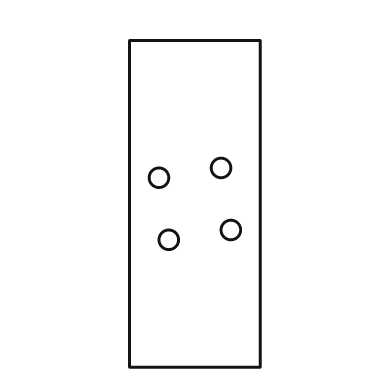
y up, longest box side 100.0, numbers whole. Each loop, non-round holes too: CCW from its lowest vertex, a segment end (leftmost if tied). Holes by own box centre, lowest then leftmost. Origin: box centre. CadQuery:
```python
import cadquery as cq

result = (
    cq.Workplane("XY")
    .moveTo(-20.0, -50.0)
    .lineTo(20.0, -50.0)
    .lineTo(20.0, 50.0)
    .lineTo(-20.0, 50.0)
    .close()
    .moveTo(-8.0, -11.0)
    .circle(3.0)
    .moveTo(11.0, -8.0)
    .circle(3.0)
    .moveTo(-11.0, 8.0)
    .circle(3.0)
    .moveTo(8.0, 11.0)
    .circle(3.0)
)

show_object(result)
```